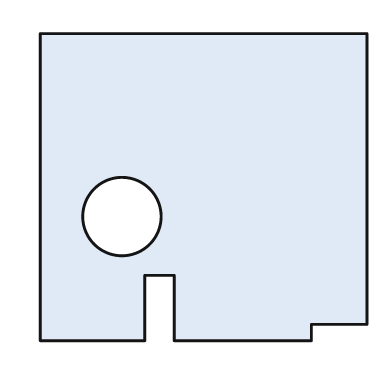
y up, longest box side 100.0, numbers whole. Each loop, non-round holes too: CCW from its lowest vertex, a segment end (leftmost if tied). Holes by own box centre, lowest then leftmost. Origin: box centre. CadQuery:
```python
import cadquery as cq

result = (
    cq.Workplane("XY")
    .moveTo(-50.0, -47.0)
    .lineTo(-18.0, -47.0)
    .lineTo(-18.0, -27.0)
    .lineTo(-9.0, -27.0)
    .lineTo(-9.0, -47.0)
    .lineTo(33.0, -47.0)
    .lineTo(33.0, -42.0)
    .lineTo(50.0, -42.0)
    .lineTo(50.0, 47.0)
    .lineTo(-50.0, 47.0)
    .close()
    .moveTo(-25.0, -9.0)
    .circle(12.0)
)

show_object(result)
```